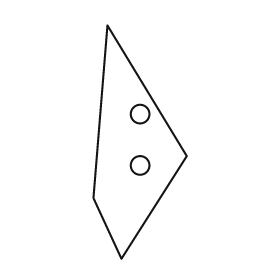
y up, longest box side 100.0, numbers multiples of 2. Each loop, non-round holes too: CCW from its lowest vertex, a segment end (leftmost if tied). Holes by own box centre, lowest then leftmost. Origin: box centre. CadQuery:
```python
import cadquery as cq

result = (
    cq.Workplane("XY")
    .moveTo(-8.0, -50.0)
    .lineTo(20.0, -6.0)
    .lineTo(-14.0, 50.0)
    .lineTo(-20.0, -24.0)
    .close()
    .moveTo(0.0, -10.0)
    .circle(4.0)
    .moveTo(0.0, 12.0)
    .circle(4.0)
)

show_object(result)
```